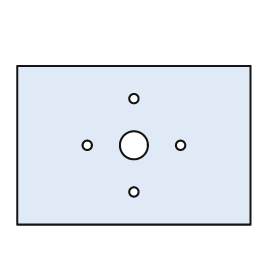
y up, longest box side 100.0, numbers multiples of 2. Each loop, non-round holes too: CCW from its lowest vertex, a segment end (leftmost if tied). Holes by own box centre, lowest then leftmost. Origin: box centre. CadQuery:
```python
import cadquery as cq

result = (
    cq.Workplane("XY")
    .moveTo(-50.0, -34.0)
    .lineTo(50.0, -34.0)
    .lineTo(50.0, 34.0)
    .lineTo(-50.0, 34.0)
    .close()
    .moveTo(0.0, -20.0)
    .circle(2.0)
    .moveTo(-20.0, 0.0)
    .circle(2.0)
    .moveTo(0.0, 0.0)
    .circle(6.0)
    .moveTo(20.0, 0.0)
    .circle(2.0)
    .moveTo(0.0, 20.0)
    .circle(2.0)
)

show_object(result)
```